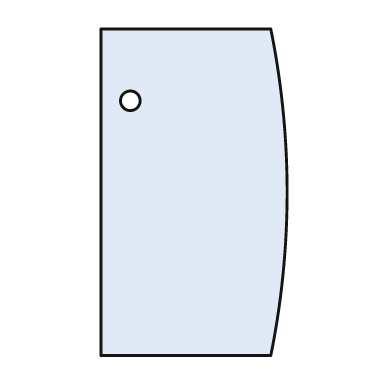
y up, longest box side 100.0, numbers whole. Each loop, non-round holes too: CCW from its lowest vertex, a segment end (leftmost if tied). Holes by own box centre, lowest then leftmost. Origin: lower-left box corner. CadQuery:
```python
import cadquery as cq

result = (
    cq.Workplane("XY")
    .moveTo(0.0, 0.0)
    .lineTo(52.0, 0.0)
    .threePointArc((57.0, 50.0), (52.0, 100.0))
    .lineTo(0.0, 100.0)
    .close()
    .moveTo(9.0, 78.0)
    .circle(3.0)
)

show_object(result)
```